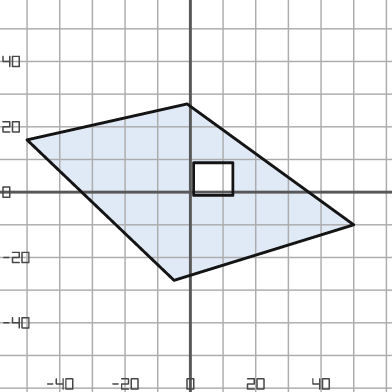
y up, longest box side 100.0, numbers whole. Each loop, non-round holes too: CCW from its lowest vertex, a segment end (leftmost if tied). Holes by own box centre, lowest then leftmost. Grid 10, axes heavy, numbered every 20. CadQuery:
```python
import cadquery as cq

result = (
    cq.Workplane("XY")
    .moveTo(-5.0, -27.0)
    .lineTo(50.0, -10.0)
    .lineTo(-1.0, 27.0)
    .lineTo(-50.0, 16.0)
    .close()
    .moveTo(1.0, -1.0)
    .lineTo(13.0, -1.0)
    .lineTo(13.0, 9.0)
    .lineTo(1.0, 9.0)
    .close()
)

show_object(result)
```